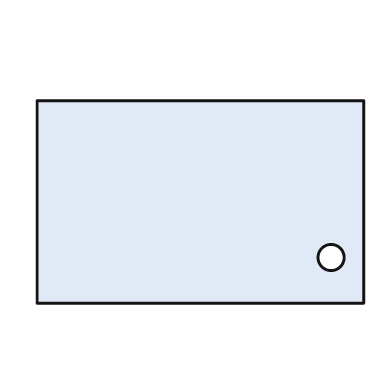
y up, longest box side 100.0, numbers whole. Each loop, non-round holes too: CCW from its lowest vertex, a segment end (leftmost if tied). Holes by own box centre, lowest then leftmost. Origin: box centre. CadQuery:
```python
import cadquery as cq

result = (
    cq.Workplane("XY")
    .moveTo(-50.0, -31.0)
    .lineTo(50.0, -31.0)
    .lineTo(50.0, 31.0)
    .lineTo(-50.0, 31.0)
    .close()
    .moveTo(40.0, -17.0)
    .circle(4.0)
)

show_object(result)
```